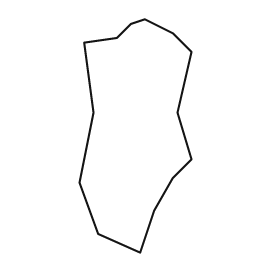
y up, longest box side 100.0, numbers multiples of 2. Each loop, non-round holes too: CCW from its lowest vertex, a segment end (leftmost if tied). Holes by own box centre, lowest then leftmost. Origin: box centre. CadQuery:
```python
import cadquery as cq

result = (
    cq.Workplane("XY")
    .moveTo(2.0, -50.0)
    .lineTo(8.0, -32.0)
    .lineTo(16.0, -18.0)
    .lineTo(24.0, -10.0)
    .lineTo(18.0, 10.0)
    .lineTo(24.0, 36.0)
    .lineTo(16.0, 44.0)
    .lineTo(4.0, 50.0)
    .lineTo(-2.0, 48.0)
    .lineTo(-8.0, 42.0)
    .lineTo(-22.0, 40.0)
    .lineTo(-18.0, 10.0)
    .lineTo(-24.0, -20.0)
    .lineTo(-16.0, -42.0)
    .close()
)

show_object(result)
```